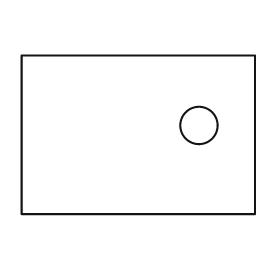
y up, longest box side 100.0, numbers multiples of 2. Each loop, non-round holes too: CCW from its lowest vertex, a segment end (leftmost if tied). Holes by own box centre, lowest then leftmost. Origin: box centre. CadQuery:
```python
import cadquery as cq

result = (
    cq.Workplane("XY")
    .moveTo(-50.0, -34.0)
    .lineTo(50.0, -34.0)
    .lineTo(50.0, 34.0)
    .lineTo(-50.0, 34.0)
    .close()
    .moveTo(26.0, 4.0)
    .circle(8.0)
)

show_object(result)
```